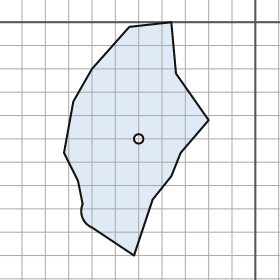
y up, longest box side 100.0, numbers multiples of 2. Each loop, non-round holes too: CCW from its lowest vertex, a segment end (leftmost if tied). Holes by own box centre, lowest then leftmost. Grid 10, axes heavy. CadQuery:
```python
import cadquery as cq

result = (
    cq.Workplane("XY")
    .moveTo(-52.0, -100.0)
    .lineTo(-44.0, -76.0)
    .lineTo(-36.0, -66.0)
    .lineTo(-32.0, -56.0)
    .lineTo(-20.0, -42.0)
    .lineTo(-34.0, -22.0)
    .lineTo(-36.0, 0.0)
    .lineTo(-54.0, -2.0)
    .lineTo(-70.0, -20.0)
    .lineTo(-78.0, -34.0)
    .lineTo(-82.0, -56.0)
    .lineTo(-76.0, -68.0)
    .lineTo(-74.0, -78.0)
    .threePointArc((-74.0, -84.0), (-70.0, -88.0))
    .close()
    .moveTo(-50.0, -50.0)
    .circle(2.0)
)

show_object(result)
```